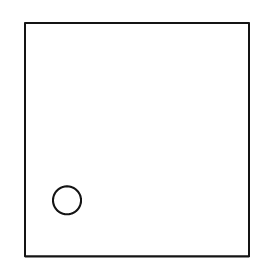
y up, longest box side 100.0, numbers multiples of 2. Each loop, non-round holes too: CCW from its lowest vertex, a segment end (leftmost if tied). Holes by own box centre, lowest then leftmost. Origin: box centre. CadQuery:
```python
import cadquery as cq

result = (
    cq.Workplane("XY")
    .moveTo(-48.0, -50.0)
    .lineTo(48.0, -50.0)
    .lineTo(48.0, 50.0)
    .lineTo(-48.0, 50.0)
    .close()
    .moveTo(-30.0, -26.0)
    .circle(6.0)
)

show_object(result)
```